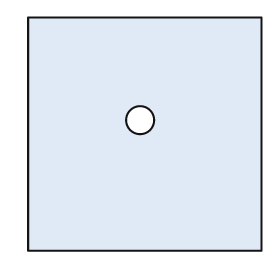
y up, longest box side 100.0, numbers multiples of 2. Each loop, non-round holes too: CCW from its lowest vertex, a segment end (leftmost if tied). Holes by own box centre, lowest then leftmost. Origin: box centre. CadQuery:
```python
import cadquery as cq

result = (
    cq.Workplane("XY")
    .moveTo(-50.0, -50.0)
    .lineTo(50.0, -50.0)
    .lineTo(50.0, 50.0)
    .lineTo(-50.0, 50.0)
    .close()
    .moveTo(-2.0, 6.0)
    .circle(6.0)
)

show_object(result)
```